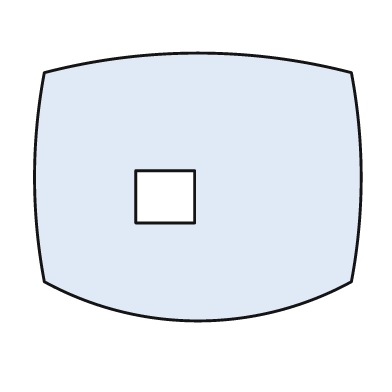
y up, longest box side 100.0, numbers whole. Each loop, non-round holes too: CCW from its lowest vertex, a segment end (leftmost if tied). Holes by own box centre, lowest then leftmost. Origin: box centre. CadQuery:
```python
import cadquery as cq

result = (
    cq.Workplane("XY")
    .moveTo(-47.0, -29.0)
    .threePointArc((0.0, -41.0), (47.0, -29.0))
    .threePointArc((50.0, 3.0), (47.0, 35.0))
    .threePointArc((0.0, 41.0), (-47.0, 35.0))
    .threePointArc((-50.0, 3.0), (-47.0, -29.0))
    .close()
    .moveTo(-19.0, -11.0)
    .lineTo(-1.0, -11.0)
    .lineTo(-1.0, 5.0)
    .lineTo(-19.0, 5.0)
    .close()
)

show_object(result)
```